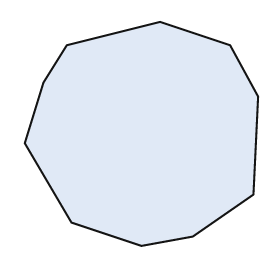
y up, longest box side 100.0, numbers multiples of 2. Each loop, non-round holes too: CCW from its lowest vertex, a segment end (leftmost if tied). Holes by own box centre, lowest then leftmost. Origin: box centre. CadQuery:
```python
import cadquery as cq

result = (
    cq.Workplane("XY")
    .moveTo(0.0, -48.0)
    .lineTo(22.0, -44.0)
    .lineTo(48.0, -26.0)
    .lineTo(50.0, 16.0)
    .lineTo(38.0, 38.0)
    .lineTo(8.0, 48.0)
    .lineTo(-32.0, 38.0)
    .lineTo(-42.0, 22.0)
    .lineTo(-50.0, -4.0)
    .lineTo(-30.0, -38.0)
    .close()
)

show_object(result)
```